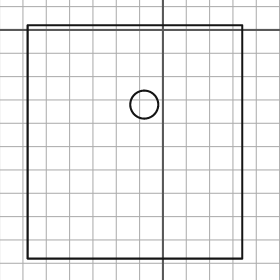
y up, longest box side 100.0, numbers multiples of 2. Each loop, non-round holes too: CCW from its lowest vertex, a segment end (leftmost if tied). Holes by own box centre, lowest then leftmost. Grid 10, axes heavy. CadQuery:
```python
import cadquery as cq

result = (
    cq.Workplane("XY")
    .moveTo(-58.0, -98.0)
    .lineTo(34.0, -98.0)
    .lineTo(34.0, 2.0)
    .lineTo(-58.0, 2.0)
    .close()
    .moveTo(-8.0, -32.0)
    .circle(6.0)
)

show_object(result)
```